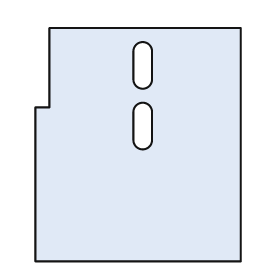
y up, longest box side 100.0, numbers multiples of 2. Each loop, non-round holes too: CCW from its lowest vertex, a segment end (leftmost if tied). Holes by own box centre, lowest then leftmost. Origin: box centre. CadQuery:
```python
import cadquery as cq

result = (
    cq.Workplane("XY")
    .moveTo(-44.0, -50.0)
    .lineTo(44.0, -50.0)
    .lineTo(44.0, 50.0)
    .lineTo(-38.0, 50.0)
    .lineTo(-38.0, 16.0)
    .lineTo(-44.0, 16.0)
    .close()
    .moveTo(-2.0, 2.0)
    .threePointArc((2.0, -2.0), (6.0, 2.0))
    .lineTo(6.0, 14.0)
    .threePointArc((2.0, 18.0), (-2.0, 14.0))
    .close()
    .moveTo(-2.0, 28.0)
    .threePointArc((2.0, 24.0), (6.0, 28.0))
    .lineTo(6.0, 40.0)
    .threePointArc((2.0, 44.0), (-2.0, 40.0))
    .close()
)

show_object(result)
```